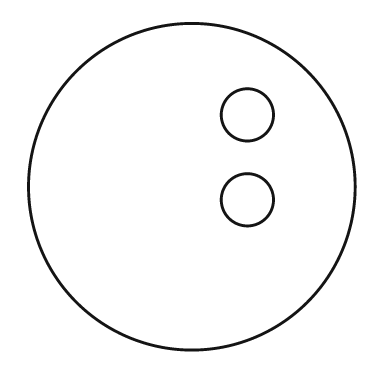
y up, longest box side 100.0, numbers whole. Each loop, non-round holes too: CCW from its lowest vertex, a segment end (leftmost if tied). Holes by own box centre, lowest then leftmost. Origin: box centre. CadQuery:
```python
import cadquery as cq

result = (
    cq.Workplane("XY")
    .moveTo(0.0, 0.0)
    .circle(50.0)
    .moveTo(17.0, -4.0)
    .circle(8.0)
    .moveTo(17.0, 22.0)
    .circle(8.0)
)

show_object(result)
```